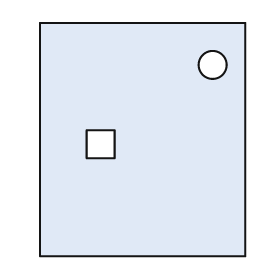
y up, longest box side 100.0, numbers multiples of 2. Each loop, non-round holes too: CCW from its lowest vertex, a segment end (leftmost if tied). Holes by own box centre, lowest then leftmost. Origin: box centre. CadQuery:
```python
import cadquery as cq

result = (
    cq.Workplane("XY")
    .moveTo(-44.0, -50.0)
    .lineTo(44.0, -50.0)
    .lineTo(44.0, 50.0)
    .lineTo(-44.0, 50.0)
    .close()
    .moveTo(-24.0, -8.0)
    .lineTo(-12.0, -8.0)
    .lineTo(-12.0, 4.0)
    .lineTo(-24.0, 4.0)
    .close()
    .moveTo(30.0, 32.0)
    .circle(6.0)
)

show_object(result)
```